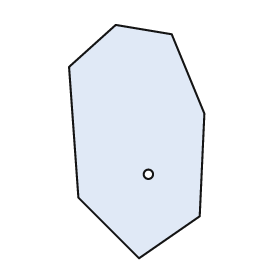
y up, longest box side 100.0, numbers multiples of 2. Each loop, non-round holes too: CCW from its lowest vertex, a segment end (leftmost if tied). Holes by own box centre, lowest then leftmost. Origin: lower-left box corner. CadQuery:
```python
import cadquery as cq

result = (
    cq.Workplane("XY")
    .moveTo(30.0, 0.0)
    .lineTo(56.0, 18.0)
    .lineTo(58.0, 62.0)
    .lineTo(44.0, 96.0)
    .lineTo(20.0, 100.0)
    .lineTo(0.0, 82.0)
    .lineTo(4.0, 26.0)
    .close()
    .moveTo(34.0, 36.0)
    .circle(2.0)
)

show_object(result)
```